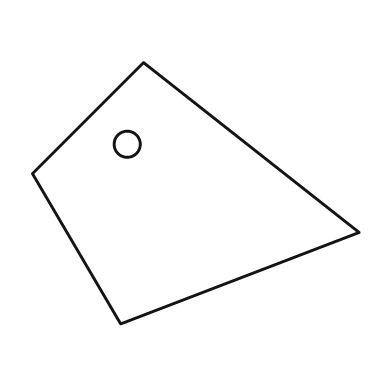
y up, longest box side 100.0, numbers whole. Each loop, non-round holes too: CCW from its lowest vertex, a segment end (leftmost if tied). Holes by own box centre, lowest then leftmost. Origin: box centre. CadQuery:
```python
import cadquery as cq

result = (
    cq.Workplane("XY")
    .moveTo(-23.0, -40.0)
    .lineTo(50.0, -12.0)
    .lineTo(-16.0, 40.0)
    .lineTo(-50.0, 6.0)
    .close()
    .moveTo(-21.0, 15.0)
    .circle(4.0)
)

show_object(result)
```